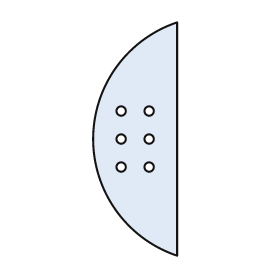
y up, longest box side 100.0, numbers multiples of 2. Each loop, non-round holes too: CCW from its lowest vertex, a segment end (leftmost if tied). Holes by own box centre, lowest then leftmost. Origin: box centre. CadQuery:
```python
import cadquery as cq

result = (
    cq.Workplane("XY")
    .moveTo(18.0, -50.0)
    .lineTo(18.0, 50.0)
    .threePointArc((-18.0, 0.0), (18.0, -50.0))
    .close()
    .moveTo(-6.0, -12.0)
    .circle(2.0)
    .moveTo(6.0, -12.0)
    .circle(2.0)
    .moveTo(-6.0, 0.0)
    .circle(2.0)
    .moveTo(6.0, 0.0)
    .circle(2.0)
    .moveTo(-6.0, 12.0)
    .circle(2.0)
    .moveTo(6.0, 12.0)
    .circle(2.0)
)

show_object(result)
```